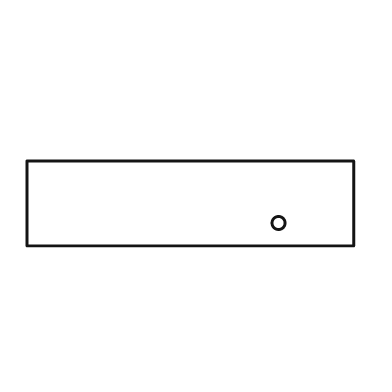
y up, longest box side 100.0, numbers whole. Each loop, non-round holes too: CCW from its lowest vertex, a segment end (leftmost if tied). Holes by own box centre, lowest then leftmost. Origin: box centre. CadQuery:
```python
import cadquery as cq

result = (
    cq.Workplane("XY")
    .moveTo(-50.0, -13.0)
    .lineTo(50.0, -13.0)
    .lineTo(50.0, 13.0)
    .lineTo(-50.0, 13.0)
    .close()
    .moveTo(27.0, -6.0)
    .circle(2.0)
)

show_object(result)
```